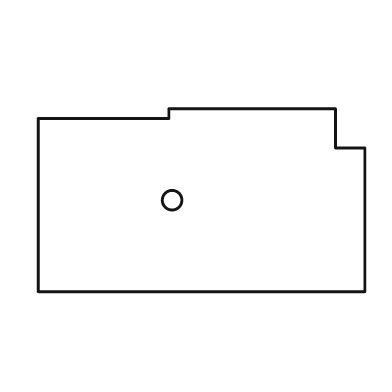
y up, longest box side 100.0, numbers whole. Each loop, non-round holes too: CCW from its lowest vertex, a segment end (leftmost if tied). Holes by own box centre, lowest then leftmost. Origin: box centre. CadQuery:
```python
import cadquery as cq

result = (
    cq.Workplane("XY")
    .moveTo(-50.0, -28.0)
    .lineTo(50.0, -28.0)
    .lineTo(50.0, 16.0)
    .lineTo(41.0, 16.0)
    .lineTo(41.0, 28.0)
    .lineTo(-10.0, 28.0)
    .lineTo(-10.0, 25.0)
    .lineTo(-50.0, 25.0)
    .close()
    .moveTo(-9.0, 0.0)
    .circle(3.0)
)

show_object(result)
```